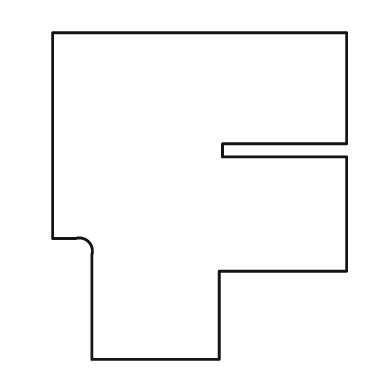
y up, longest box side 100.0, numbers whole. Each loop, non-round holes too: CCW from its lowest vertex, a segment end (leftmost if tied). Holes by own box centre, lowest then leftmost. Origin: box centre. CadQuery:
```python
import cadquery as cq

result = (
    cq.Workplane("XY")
    .moveTo(-33.0, -50.0)
    .lineTo(6.0, -50.0)
    .lineTo(6.0, -23.0)
    .lineTo(45.0, -23.0)
    .lineTo(45.0, 12.0)
    .lineTo(7.0, 12.0)
    .lineTo(7.0, 16.0)
    .lineTo(45.0, 16.0)
    .lineTo(45.0, 50.0)
    .lineTo(-45.0, 50.0)
    .lineTo(-45.0, -13.0)
    .lineTo(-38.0, -13.0)
    .threePointArc((-34.0, -14.0), (-33.0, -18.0))
    .close()
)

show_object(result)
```